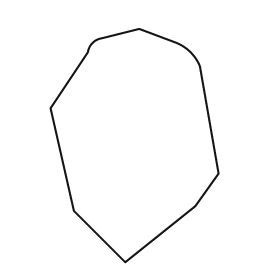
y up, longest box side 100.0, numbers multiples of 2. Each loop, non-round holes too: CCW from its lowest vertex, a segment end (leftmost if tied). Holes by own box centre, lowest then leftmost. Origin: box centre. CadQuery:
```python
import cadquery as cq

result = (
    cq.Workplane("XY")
    .moveTo(-4.0, -50.0)
    .lineTo(26.0, -26.0)
    .lineTo(36.0, -12.0)
    .lineTo(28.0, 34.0)
    .threePointArc((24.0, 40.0), (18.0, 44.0))
    .lineTo(2.0, 50.0)
    .lineTo(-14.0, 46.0)
    .threePointArc((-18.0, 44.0), (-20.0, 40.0))
    .lineTo(-36.0, 16.0)
    .lineTo(-26.0, -28.0)
    .close()
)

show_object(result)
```